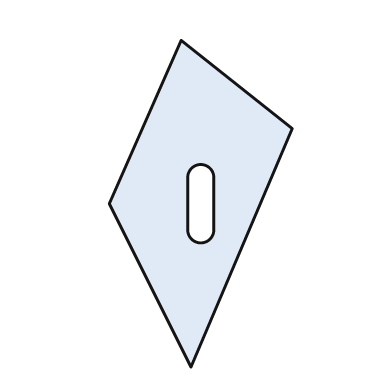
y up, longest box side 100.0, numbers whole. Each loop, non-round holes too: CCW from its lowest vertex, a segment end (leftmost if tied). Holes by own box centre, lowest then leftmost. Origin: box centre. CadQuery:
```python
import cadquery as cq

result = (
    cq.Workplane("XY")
    .moveTo(-3.0, -50.0)
    .lineTo(28.0, 23.0)
    .lineTo(-6.0, 50.0)
    .lineTo(-28.0, 0.0)
    .close()
    .moveTo(-4.0, -8.0)
    .threePointArc((0.0, -12.0), (4.0, -8.0))
    .lineTo(4.0, 8.0)
    .threePointArc((0.0, 12.0), (-4.0, 8.0))
    .close()
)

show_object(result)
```